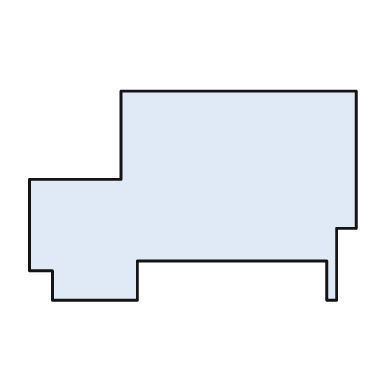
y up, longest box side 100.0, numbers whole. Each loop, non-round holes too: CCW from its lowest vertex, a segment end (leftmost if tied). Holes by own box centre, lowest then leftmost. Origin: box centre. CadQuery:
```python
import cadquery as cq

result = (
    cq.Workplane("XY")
    .moveTo(-43.0, -32.0)
    .lineTo(-17.0, -32.0)
    .lineTo(-17.0, -20.0)
    .lineTo(41.0, -20.0)
    .lineTo(41.0, -32.0)
    .lineTo(44.0, -32.0)
    .lineTo(44.0, -10.0)
    .lineTo(50.0, -10.0)
    .lineTo(50.0, 32.0)
    .lineTo(-22.0, 32.0)
    .lineTo(-22.0, 5.0)
    .lineTo(-50.0, 5.0)
    .lineTo(-50.0, -23.0)
    .lineTo(-43.0, -23.0)
    .close()
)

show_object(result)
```